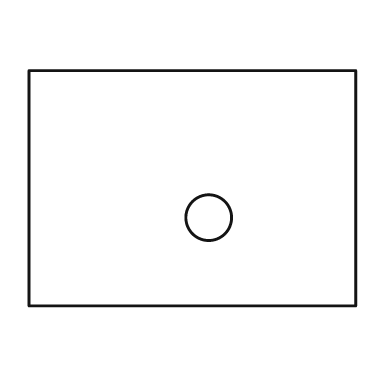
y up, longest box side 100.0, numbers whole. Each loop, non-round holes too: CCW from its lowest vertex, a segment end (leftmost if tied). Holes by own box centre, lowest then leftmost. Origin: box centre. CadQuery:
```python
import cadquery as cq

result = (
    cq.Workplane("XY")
    .moveTo(-50.0, -36.0)
    .lineTo(50.0, -36.0)
    .lineTo(50.0, 36.0)
    .lineTo(-50.0, 36.0)
    .close()
    .moveTo(5.0, -9.0)
    .circle(7.0)
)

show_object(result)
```